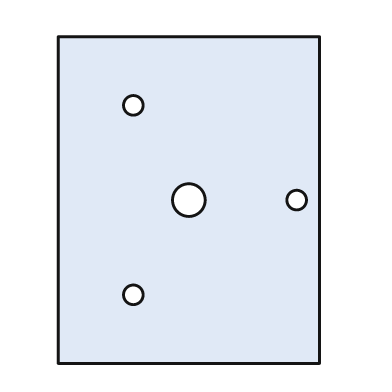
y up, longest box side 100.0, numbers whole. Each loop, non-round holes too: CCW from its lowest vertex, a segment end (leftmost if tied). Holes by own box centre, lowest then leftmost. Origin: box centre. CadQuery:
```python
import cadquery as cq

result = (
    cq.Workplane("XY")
    .moveTo(-40.0, -50.0)
    .lineTo(40.0, -50.0)
    .lineTo(40.0, 50.0)
    .lineTo(-40.0, 50.0)
    .close()
    .moveTo(-17.0, -29.0)
    .circle(3.0)
    .moveTo(0.0, 0.0)
    .circle(5.0)
    .moveTo(33.0, 0.0)
    .circle(3.0)
    .moveTo(-17.0, 29.0)
    .circle(3.0)
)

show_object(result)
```